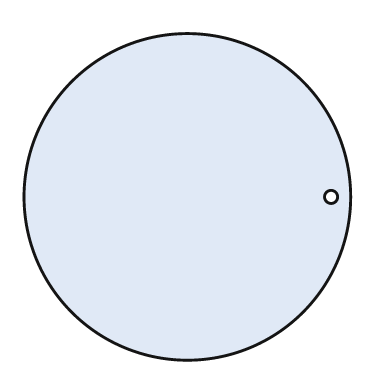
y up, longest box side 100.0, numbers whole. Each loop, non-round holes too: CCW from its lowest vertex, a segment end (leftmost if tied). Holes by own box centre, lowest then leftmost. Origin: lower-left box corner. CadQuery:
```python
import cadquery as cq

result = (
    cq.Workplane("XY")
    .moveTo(50.0, 50.0)
    .circle(50.0)
    .moveTo(94.0, 50.0)
    .circle(2.0)
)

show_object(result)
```